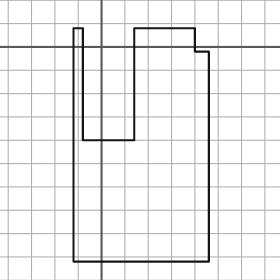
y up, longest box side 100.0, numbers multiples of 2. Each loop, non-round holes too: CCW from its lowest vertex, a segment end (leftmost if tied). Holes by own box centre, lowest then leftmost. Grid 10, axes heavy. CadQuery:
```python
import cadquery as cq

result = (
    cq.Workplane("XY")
    .moveTo(-12.0, -92.0)
    .lineTo(46.0, -92.0)
    .lineTo(46.0, -2.0)
    .lineTo(40.0, -2.0)
    .lineTo(40.0, 8.0)
    .lineTo(14.0, 8.0)
    .lineTo(14.0, -40.0)
    .lineTo(-8.0, -40.0)
    .lineTo(-8.0, 8.0)
    .lineTo(-12.0, 8.0)
    .close()
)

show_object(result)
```